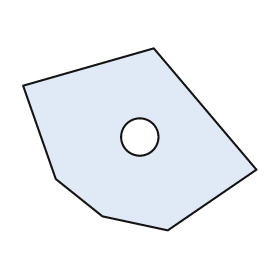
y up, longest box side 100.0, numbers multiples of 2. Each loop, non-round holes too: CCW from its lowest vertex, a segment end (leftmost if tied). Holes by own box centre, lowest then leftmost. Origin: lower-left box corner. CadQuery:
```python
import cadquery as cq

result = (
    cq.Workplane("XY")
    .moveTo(62.0, 0.0)
    .lineTo(100.0, 26.0)
    .lineTo(56.0, 78.0)
    .lineTo(0.0, 62.0)
    .lineTo(14.0, 22.0)
    .lineTo(34.0, 6.0)
    .close()
    .moveTo(50.0, 40.0)
    .circle(8.0)
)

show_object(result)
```